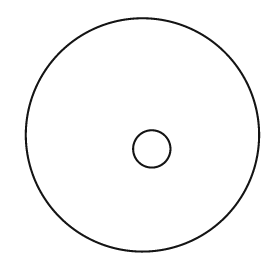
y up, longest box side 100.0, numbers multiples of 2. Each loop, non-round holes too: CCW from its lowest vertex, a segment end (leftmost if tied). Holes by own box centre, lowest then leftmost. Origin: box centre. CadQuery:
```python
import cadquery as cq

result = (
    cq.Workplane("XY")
    .moveTo(0.0, 0.0)
    .circle(50.0)
    .moveTo(4.0, -6.0)
    .circle(8.0)
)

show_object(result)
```